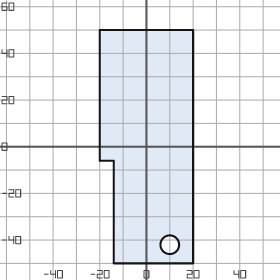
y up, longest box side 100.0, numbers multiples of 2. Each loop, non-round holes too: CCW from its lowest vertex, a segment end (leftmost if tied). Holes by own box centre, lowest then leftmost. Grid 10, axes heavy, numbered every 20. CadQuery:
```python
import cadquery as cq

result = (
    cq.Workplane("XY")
    .moveTo(-14.0, -50.0)
    .lineTo(20.0, -50.0)
    .lineTo(20.0, 50.0)
    .lineTo(-20.0, 50.0)
    .lineTo(-20.0, -6.0)
    .lineTo(-14.0, -6.0)
    .close()
    .moveTo(10.0, -42.0)
    .circle(4.0)
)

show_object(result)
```